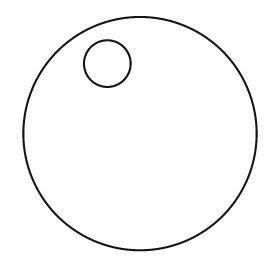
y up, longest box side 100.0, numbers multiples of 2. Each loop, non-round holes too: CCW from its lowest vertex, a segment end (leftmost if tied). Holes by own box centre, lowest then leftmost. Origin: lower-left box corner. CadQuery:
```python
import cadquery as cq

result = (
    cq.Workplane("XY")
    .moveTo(50.0, 50.0)
    .circle(50.0)
    .moveTo(36.0, 80.0)
    .circle(10.0)
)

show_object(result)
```